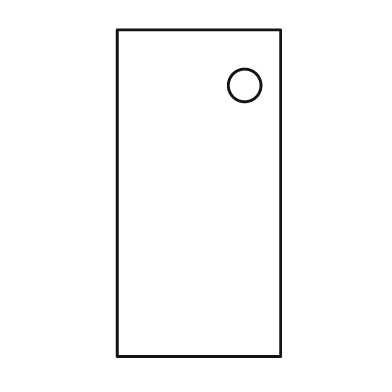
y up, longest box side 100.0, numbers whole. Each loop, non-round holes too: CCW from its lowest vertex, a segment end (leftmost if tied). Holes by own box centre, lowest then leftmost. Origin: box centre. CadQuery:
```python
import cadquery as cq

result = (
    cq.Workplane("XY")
    .moveTo(-25.0, -50.0)
    .lineTo(25.0, -50.0)
    .lineTo(25.0, 50.0)
    .lineTo(-25.0, 50.0)
    .close()
    .moveTo(14.0, 33.0)
    .circle(5.0)
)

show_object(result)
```